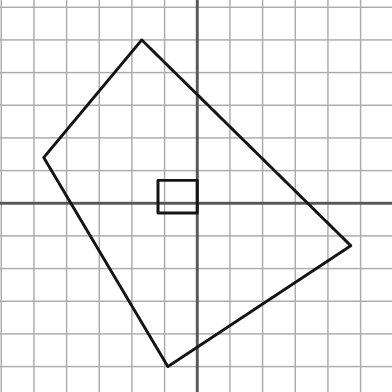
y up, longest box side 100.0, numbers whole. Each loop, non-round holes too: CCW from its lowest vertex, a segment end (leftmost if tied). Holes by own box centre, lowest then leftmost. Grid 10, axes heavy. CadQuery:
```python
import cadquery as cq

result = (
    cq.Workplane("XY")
    .moveTo(-9.0, -50.0)
    .lineTo(47.0, -13.0)
    .lineTo(-17.0, 50.0)
    .lineTo(-47.0, 14.0)
    .close()
    .moveTo(-12.0, -3.0)
    .lineTo(0.0, -3.0)
    .lineTo(0.0, 7.0)
    .lineTo(-12.0, 7.0)
    .close()
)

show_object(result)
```